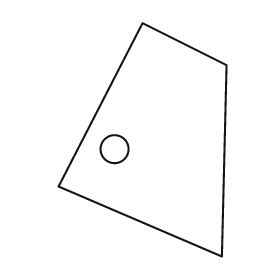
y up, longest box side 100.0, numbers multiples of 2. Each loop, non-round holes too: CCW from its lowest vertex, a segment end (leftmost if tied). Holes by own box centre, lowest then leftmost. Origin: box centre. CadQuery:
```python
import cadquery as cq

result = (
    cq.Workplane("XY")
    .moveTo(34.0, -50.0)
    .lineTo(36.0, 32.0)
    .lineTo(0.0, 50.0)
    .lineTo(-36.0, -20.0)
    .close()
    .moveTo(-12.0, -4.0)
    .circle(6.0)
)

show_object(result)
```